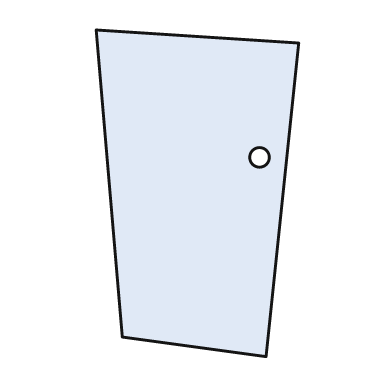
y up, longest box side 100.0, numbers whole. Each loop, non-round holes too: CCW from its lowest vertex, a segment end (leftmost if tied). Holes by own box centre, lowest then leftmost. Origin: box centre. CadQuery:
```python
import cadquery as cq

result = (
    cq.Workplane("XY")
    .moveTo(21.0, -50.0)
    .lineTo(31.0, 46.0)
    .lineTo(-31.0, 50.0)
    .lineTo(-23.0, -44.0)
    .close()
    .moveTo(19.0, 11.0)
    .circle(3.0)
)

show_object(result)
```